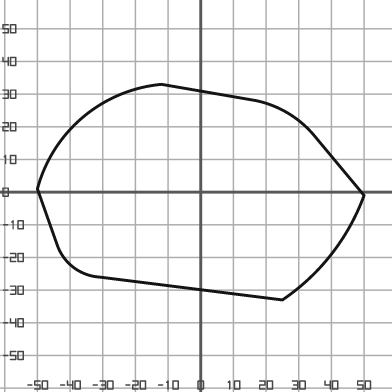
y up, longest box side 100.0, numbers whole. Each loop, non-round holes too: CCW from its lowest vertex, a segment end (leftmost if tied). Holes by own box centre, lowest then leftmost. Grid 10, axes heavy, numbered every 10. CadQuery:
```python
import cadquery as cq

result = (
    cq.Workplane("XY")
    .moveTo(25.0, -33.0)
    .threePointArc((40.0, -19.0), (50.0, -1.0))
    .lineTo(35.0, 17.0)
    .threePointArc((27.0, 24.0), (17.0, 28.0))
    .lineTo(-12.0, 33.0)
    .threePointArc((-36.0, 23.0), (-50.0, 1.0))
    .lineTo(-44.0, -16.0)
    .threePointArc((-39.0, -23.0), (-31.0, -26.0))
    .close()
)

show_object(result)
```